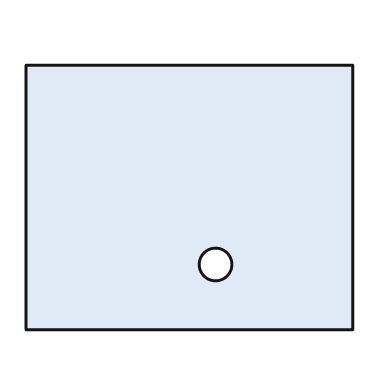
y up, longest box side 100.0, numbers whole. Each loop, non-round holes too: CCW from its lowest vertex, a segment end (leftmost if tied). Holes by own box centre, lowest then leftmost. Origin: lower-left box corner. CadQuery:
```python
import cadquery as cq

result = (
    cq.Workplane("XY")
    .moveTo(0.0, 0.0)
    .lineTo(100.0, 0.0)
    .lineTo(100.0, 81.0)
    .lineTo(0.0, 81.0)
    .close()
    .moveTo(58.0, 20.0)
    .circle(5.0)
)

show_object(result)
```